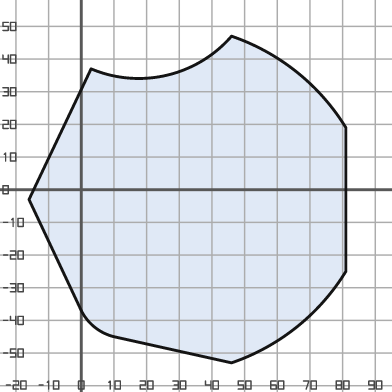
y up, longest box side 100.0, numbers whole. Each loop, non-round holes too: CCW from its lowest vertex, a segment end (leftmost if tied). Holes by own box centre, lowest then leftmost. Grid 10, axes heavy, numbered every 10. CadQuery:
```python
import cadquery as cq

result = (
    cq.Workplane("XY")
    .moveTo(46.0, -53.0)
    .threePointArc((66.0, -42.0), (81.0, -25.0))
    .lineTo(81.0, 19.0)
    .threePointArc((66.0, 36.0), (46.0, 47.0))
    .threePointArc((26.0, 35.0), (3.0, 37.0))
    .lineTo(-16.0, -3.0)
    .lineTo(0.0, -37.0)
    .threePointArc((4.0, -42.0), (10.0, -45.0))
    .close()
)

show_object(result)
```